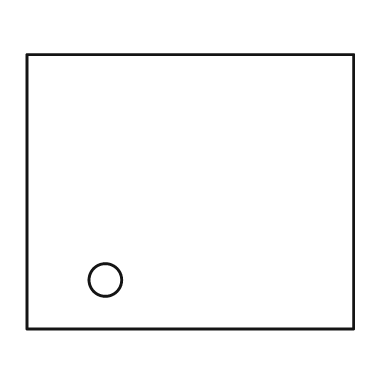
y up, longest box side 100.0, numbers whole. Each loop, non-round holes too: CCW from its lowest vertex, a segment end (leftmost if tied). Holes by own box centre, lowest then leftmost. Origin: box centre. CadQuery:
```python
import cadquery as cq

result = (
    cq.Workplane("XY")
    .moveTo(-50.0, -42.0)
    .lineTo(50.0, -42.0)
    .lineTo(50.0, 42.0)
    .lineTo(-50.0, 42.0)
    .close()
    .moveTo(-26.0, -27.0)
    .circle(5.0)
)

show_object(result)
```